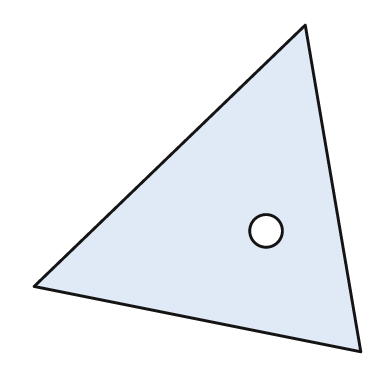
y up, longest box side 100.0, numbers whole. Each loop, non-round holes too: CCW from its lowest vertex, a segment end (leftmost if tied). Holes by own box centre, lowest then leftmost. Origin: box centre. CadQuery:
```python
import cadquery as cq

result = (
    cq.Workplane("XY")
    .moveTo(50.0, -50.0)
    .lineTo(33.0, 50.0)
    .lineTo(-50.0, -30.0)
    .close()
    .moveTo(21.0, -13.0)
    .circle(5.0)
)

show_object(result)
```